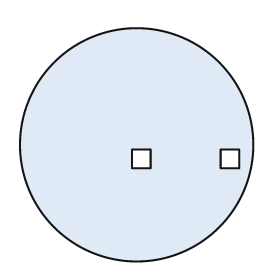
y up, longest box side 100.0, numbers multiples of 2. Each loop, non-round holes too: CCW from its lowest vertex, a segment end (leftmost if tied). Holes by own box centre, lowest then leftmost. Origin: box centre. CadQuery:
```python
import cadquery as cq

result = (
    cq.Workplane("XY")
    .moveTo(0.0, 0.0)
    .circle(50.0)
    .moveTo(-2.0, -10.0)
    .lineTo(6.0, -10.0)
    .lineTo(6.0, -2.0)
    .lineTo(-2.0, -2.0)
    .close()
    .moveTo(36.0, -10.0)
    .lineTo(44.0, -10.0)
    .lineTo(44.0, -2.0)
    .lineTo(36.0, -2.0)
    .close()
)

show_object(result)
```